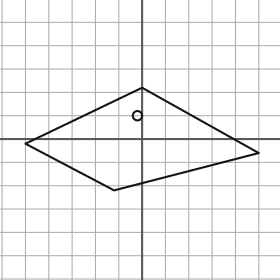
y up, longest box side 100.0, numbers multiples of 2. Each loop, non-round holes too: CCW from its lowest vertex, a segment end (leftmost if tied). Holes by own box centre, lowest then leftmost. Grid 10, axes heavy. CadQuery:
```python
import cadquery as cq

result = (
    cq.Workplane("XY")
    .moveTo(-12.0, -22.0)
    .lineTo(50.0, -6.0)
    .lineTo(0.0, 22.0)
    .lineTo(-50.0, -2.0)
    .close()
    .moveTo(-2.0, 10.0)
    .circle(2.0)
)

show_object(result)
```